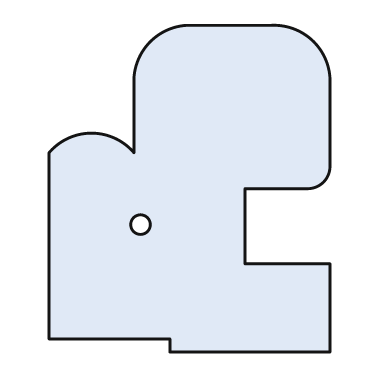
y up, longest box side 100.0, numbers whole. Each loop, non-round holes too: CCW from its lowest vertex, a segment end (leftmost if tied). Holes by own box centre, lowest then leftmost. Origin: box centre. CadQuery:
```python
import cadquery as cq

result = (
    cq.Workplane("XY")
    .moveTo(-6.0, -50.0)
    .lineTo(43.0, -50.0)
    .lineTo(43.0, -23.0)
    .lineTo(17.0, -23.0)
    .lineTo(17.0, 0.0)
    .lineTo(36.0, 0.0)
    .threePointArc((41.0, 2.0), (43.0, 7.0))
    .lineTo(43.0, 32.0)
    .threePointArc((38.0, 45.0), (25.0, 50.0))
    .lineTo(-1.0, 50.0)
    .threePointArc((-12.0, 45.0), (-17.0, 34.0))
    .lineTo(-17.0, 11.0)
    .threePointArc((-30.0, 17.0), (-43.0, 11.0))
    .lineTo(-43.0, -46.0)
    .lineTo(-6.0, -46.0)
    .close()
    .moveTo(-15.0, -11.0)
    .circle(3.0)
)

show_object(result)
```